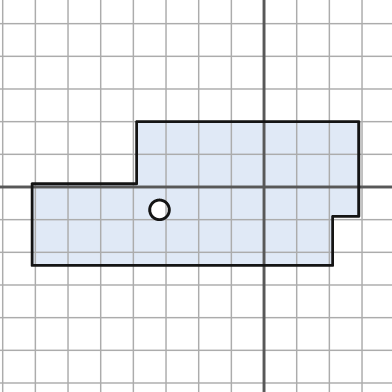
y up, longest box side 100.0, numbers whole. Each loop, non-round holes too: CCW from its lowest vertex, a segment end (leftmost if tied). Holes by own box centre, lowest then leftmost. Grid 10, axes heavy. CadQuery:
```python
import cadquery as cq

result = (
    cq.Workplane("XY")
    .moveTo(-71.0, -24.0)
    .lineTo(21.0, -24.0)
    .lineTo(21.0, -9.0)
    .lineTo(29.0, -9.0)
    .lineTo(29.0, 20.0)
    .lineTo(-39.0, 20.0)
    .lineTo(-39.0, 1.0)
    .lineTo(-71.0, 1.0)
    .close()
    .moveTo(-32.0, -7.0)
    .circle(3.0)
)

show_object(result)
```